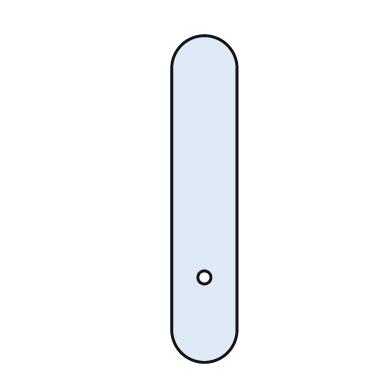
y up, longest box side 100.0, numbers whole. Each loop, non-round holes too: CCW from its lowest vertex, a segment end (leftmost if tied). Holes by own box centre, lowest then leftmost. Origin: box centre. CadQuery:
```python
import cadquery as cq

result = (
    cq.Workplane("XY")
    .moveTo(-10.0, -40.0)
    .threePointArc((0.0, -50.0), (10.0, -40.0))
    .lineTo(10.0, 40.0)
    .threePointArc((0.0, 50.0), (-10.0, 40.0))
    .close()
    .moveTo(0.0, -24.0)
    .circle(2.0)
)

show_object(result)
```